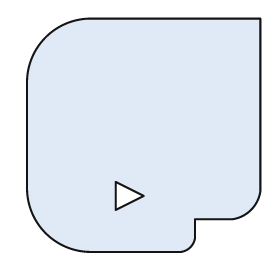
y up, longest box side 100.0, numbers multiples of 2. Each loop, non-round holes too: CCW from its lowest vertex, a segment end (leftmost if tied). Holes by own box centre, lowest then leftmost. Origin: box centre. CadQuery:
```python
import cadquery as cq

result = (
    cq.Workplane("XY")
    .moveTo(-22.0, -50.0)
    .lineTo(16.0, -50.0)
    .threePointArc((20.0, -48.0), (22.0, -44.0))
    .lineTo(22.0, -36.0)
    .lineTo(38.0, -36.0)
    .threePointArc((46.0, -32.0), (50.0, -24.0))
    .lineTo(50.0, 50.0)
    .lineTo(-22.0, 50.0)
    .threePointArc((-42.0, 42.0), (-50.0, 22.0))
    .lineTo(-50.0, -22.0)
    .threePointArc((-42.0, -42.0), (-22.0, -50.0))
    .close()
    .moveTo(-12.0, -32.0)
    .lineTo(0.0, -26.0)
    .lineTo(-12.0, -20.0)
    .close()
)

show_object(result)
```